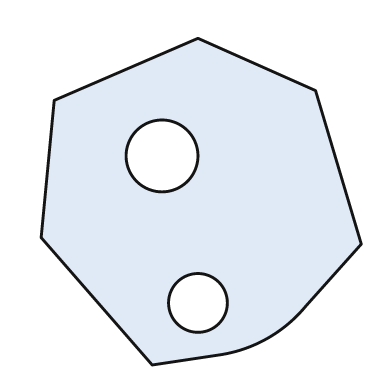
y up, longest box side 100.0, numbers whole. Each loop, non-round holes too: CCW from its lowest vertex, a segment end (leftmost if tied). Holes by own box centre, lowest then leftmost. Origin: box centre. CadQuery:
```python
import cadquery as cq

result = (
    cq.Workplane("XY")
    .moveTo(-15.0, -50.0)
    .lineTo(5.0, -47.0)
    .threePointArc((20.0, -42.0), (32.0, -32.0))
    .lineTo(49.0, -13.0)
    .lineTo(35.0, 34.0)
    .lineTo(-1.0, 50.0)
    .lineTo(-45.0, 31.0)
    .lineTo(-49.0, -11.0)
    .close()
    .moveTo(-1.0, -31.0)
    .circle(9.0)
    .moveTo(-12.0, 14.0)
    .circle(11.0)
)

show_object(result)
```